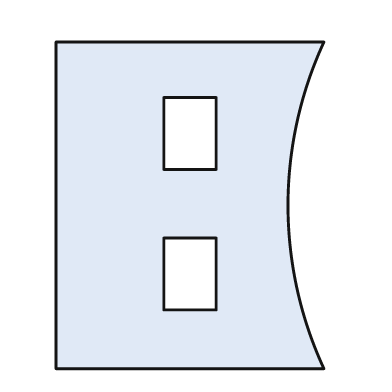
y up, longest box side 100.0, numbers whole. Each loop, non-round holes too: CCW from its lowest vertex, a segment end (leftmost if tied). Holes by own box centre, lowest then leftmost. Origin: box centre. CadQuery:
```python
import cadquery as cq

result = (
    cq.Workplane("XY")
    .moveTo(-41.0, -50.0)
    .lineTo(41.0, -50.0)
    .threePointArc((30.0, 0.0), (41.0, 50.0))
    .lineTo(-41.0, 50.0)
    .close()
    .moveTo(-8.0, -32.0)
    .lineTo(8.0, -32.0)
    .lineTo(8.0, -10.0)
    .lineTo(-8.0, -10.0)
    .close()
    .moveTo(-8.0, 11.0)
    .lineTo(8.0, 11.0)
    .lineTo(8.0, 33.0)
    .lineTo(-8.0, 33.0)
    .close()
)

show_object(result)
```